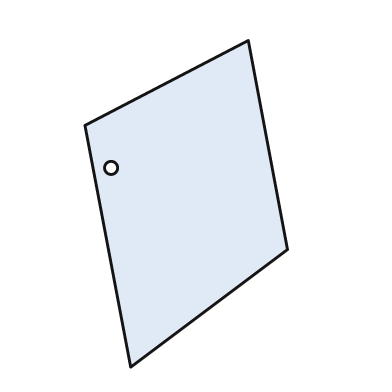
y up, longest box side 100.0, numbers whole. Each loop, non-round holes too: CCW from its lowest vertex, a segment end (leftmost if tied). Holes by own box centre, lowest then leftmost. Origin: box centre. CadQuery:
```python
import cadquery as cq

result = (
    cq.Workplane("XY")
    .moveTo(-17.0, -50.0)
    .lineTo(31.0, -14.0)
    .lineTo(19.0, 50.0)
    .lineTo(-31.0, 24.0)
    .close()
    .moveTo(-23.0, 11.0)
    .circle(2.0)
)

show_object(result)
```